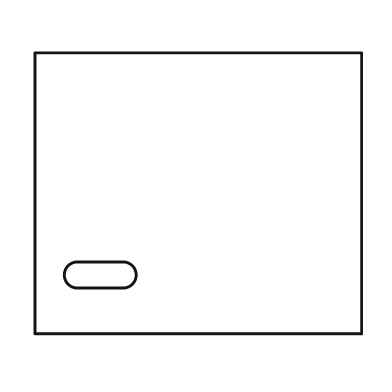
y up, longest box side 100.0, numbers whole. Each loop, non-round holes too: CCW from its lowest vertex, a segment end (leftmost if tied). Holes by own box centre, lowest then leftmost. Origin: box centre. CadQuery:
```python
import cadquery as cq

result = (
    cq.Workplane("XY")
    .moveTo(-50.0, -43.0)
    .lineTo(50.0, -43.0)
    .lineTo(50.0, 43.0)
    .lineTo(-50.0, 43.0)
    .close()
    .moveTo(-37.0, -29.0)
    .lineTo(-23.0, -29.0)
    .threePointArc((-19.0, -25.0), (-23.0, -21.0))
    .lineTo(-37.0, -21.0)
    .threePointArc((-41.0, -25.0), (-37.0, -29.0))
    .close()
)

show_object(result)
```